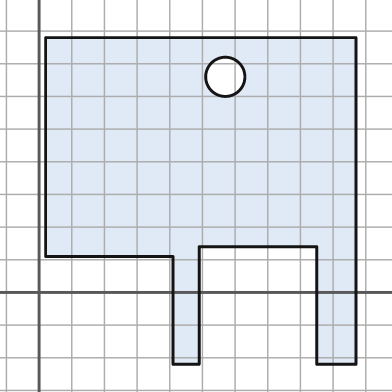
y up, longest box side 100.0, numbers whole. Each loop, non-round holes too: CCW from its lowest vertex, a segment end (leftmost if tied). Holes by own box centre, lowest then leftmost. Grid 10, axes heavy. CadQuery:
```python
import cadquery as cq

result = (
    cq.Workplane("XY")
    .moveTo(41.0, -22.0)
    .lineTo(49.0, -22.0)
    .lineTo(49.0, 14.0)
    .lineTo(85.0, 14.0)
    .lineTo(85.0, -22.0)
    .lineTo(97.0, -22.0)
    .lineTo(97.0, 78.0)
    .lineTo(2.0, 78.0)
    .lineTo(2.0, 11.0)
    .lineTo(41.0, 11.0)
    .close()
    .moveTo(57.0, 66.0)
    .circle(6.0)
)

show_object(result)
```